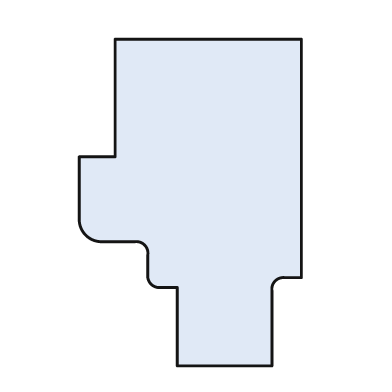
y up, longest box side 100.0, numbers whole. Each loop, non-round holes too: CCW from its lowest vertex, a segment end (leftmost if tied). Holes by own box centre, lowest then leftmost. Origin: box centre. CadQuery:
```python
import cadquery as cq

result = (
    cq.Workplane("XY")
    .moveTo(-4.0, -50.0)
    .lineTo(25.0, -50.0)
    .lineTo(25.0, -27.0)
    .threePointArc((26.0, -24.0), (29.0, -23.0))
    .lineTo(34.0, -23.0)
    .lineTo(34.0, 50.0)
    .lineTo(-23.0, 50.0)
    .lineTo(-23.0, 14.0)
    .lineTo(-34.0, 14.0)
    .lineTo(-34.0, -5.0)
    .threePointArc((-32.0, -10.0), (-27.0, -12.0))
    .lineTo(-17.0, -12.0)
    .threePointArc((-14.0, -13.0), (-13.0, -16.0))
    .lineTo(-13.0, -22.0)
    .threePointArc((-12.0, -25.0), (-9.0, -26.0))
    .lineTo(-4.0, -26.0)
    .close()
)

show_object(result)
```